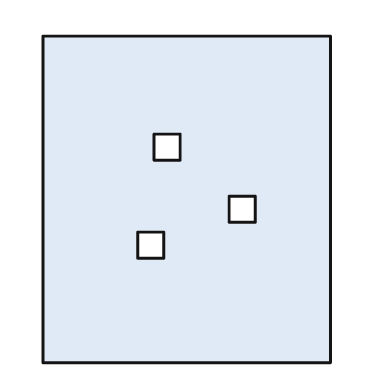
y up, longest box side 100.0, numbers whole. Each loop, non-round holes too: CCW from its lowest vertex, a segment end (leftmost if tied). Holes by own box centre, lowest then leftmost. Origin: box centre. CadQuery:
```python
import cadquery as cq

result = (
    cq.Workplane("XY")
    .moveTo(-44.0, -50.0)
    .lineTo(44.0, -50.0)
    .lineTo(44.0, 50.0)
    .lineTo(-44.0, 50.0)
    .close()
    .moveTo(-15.0, -18.0)
    .lineTo(-7.0, -18.0)
    .lineTo(-7.0, -10.0)
    .lineTo(-15.0, -10.0)
    .close()
    .moveTo(13.0, -7.0)
    .lineTo(21.0, -7.0)
    .lineTo(21.0, 1.0)
    .lineTo(13.0, 1.0)
    .close()
    .moveTo(-10.0, 12.0)
    .lineTo(-2.0, 12.0)
    .lineTo(-2.0, 20.0)
    .lineTo(-10.0, 20.0)
    .close()
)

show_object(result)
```